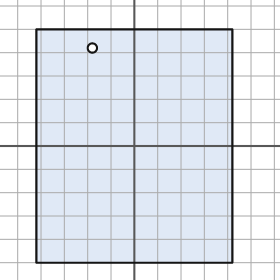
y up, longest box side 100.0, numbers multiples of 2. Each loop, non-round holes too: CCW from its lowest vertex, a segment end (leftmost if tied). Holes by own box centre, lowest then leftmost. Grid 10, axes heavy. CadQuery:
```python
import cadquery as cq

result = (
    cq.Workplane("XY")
    .moveTo(-42.0, -50.0)
    .lineTo(42.0, -50.0)
    .lineTo(42.0, 50.0)
    .lineTo(-42.0, 50.0)
    .close()
    .moveTo(-18.0, 42.0)
    .circle(2.0)
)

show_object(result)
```